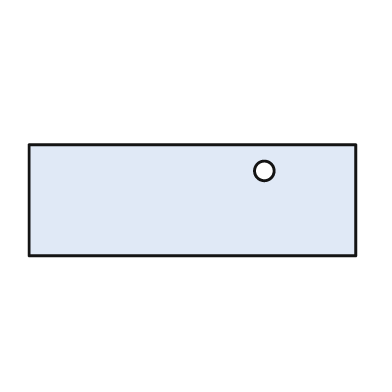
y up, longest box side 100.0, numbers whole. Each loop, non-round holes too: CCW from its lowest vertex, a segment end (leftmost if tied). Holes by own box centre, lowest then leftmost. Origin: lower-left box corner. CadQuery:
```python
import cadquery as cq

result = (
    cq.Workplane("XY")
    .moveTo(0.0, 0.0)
    .lineTo(100.0, 0.0)
    .lineTo(100.0, 34.0)
    .lineTo(0.0, 34.0)
    .close()
    .moveTo(72.0, 26.0)
    .circle(3.0)
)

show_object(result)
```